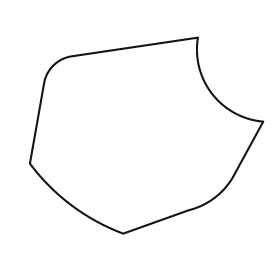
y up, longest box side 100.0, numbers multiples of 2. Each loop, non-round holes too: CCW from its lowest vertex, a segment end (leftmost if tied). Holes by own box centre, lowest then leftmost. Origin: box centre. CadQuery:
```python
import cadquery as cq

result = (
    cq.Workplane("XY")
    .moveTo(-10.0, -42.0)
    .lineTo(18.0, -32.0)
    .threePointArc((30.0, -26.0), (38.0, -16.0))
    .lineTo(50.0, 6.0)
    .threePointArc((28.0, 18.0), (22.0, 42.0))
    .lineTo(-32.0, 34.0)
    .threePointArc((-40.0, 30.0), (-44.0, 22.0))
    .lineTo(-50.0, -12.0)
    .threePointArc((-32.0, -30.0), (-10.0, -42.0))
    .close()
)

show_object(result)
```